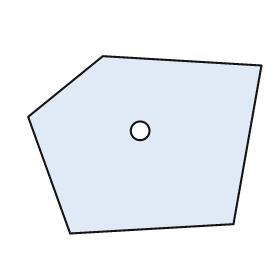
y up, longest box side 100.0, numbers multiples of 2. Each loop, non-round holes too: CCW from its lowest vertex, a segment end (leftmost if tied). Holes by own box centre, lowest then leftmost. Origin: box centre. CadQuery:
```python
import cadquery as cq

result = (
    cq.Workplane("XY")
    .moveTo(-32.0, -38.0)
    .lineTo(38.0, -34.0)
    .lineTo(50.0, 34.0)
    .lineTo(-18.0, 38.0)
    .lineTo(-50.0, 12.0)
    .close()
    .moveTo(-2.0, 6.0)
    .circle(4.0)
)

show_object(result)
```